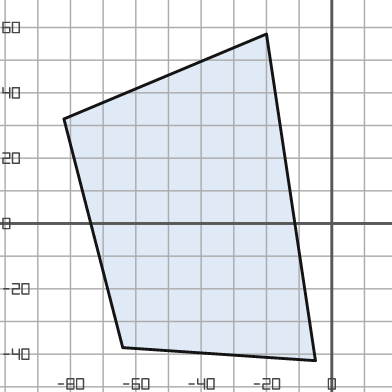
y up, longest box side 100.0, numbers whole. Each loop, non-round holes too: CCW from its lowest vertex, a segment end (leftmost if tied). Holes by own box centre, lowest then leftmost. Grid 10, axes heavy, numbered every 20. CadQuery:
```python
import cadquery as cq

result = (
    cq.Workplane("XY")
    .moveTo(-5.0, -42.0)
    .lineTo(-20.0, 58.0)
    .lineTo(-82.0, 32.0)
    .lineTo(-64.0, -38.0)
    .close()
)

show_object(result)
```